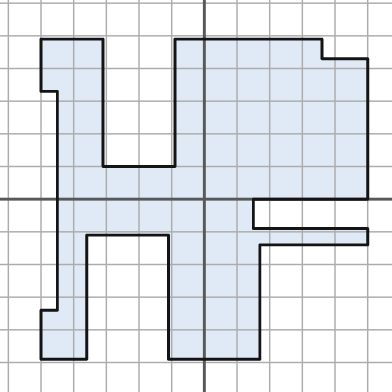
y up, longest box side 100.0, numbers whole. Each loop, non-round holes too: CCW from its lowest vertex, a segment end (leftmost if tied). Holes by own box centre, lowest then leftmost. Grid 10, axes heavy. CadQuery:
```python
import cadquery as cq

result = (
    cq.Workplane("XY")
    .moveTo(-50.0, -49.0)
    .lineTo(-36.0, -49.0)
    .lineTo(-36.0, -11.0)
    .lineTo(-11.0, -11.0)
    .lineTo(-11.0, -49.0)
    .lineTo(17.0, -49.0)
    .lineTo(17.0, -14.0)
    .lineTo(50.0, -14.0)
    .lineTo(50.0, -9.0)
    .lineTo(15.0, -9.0)
    .lineTo(15.0, 0.0)
    .lineTo(50.0, 0.0)
    .lineTo(50.0, 43.0)
    .lineTo(36.0, 43.0)
    .lineTo(36.0, 49.0)
    .lineTo(-9.0, 49.0)
    .lineTo(-9.0, 10.0)
    .lineTo(-31.0, 10.0)
    .lineTo(-31.0, 49.0)
    .lineTo(-50.0, 49.0)
    .lineTo(-50.0, 33.0)
    .lineTo(-45.0, 33.0)
    .lineTo(-45.0, -34.0)
    .lineTo(-50.0, -34.0)
    .close()
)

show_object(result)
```